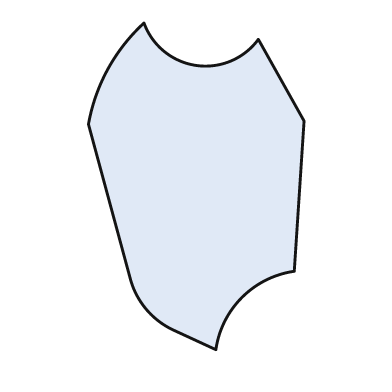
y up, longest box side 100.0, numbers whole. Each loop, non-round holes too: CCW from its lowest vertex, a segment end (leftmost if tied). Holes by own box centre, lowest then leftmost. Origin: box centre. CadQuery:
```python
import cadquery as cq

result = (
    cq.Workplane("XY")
    .moveTo(6.0, -50.0)
    .threePointArc((14.0, -34.0), (30.0, -26.0))
    .lineTo(33.0, 20.0)
    .lineTo(19.0, 45.0)
    .threePointArc((0.0, 37.0), (-16.0, 50.0))
    .threePointArc((-27.0, 36.0), (-33.0, 19.0))
    .lineTo(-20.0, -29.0)
    .threePointArc((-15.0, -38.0), (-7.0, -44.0))
    .close()
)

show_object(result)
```